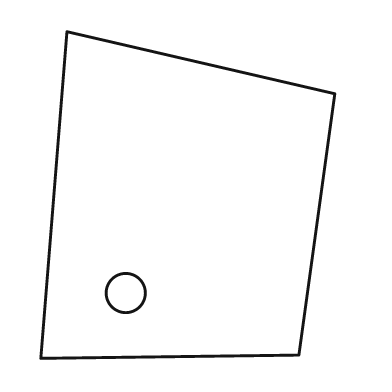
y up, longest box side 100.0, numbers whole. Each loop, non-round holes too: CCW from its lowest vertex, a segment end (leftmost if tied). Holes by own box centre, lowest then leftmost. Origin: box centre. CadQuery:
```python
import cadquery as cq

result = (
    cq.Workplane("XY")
    .moveTo(-45.0, -50.0)
    .lineTo(34.0, -49.0)
    .lineTo(45.0, 31.0)
    .lineTo(-37.0, 50.0)
    .close()
    .moveTo(-19.0, -30.0)
    .circle(6.0)
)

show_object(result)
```